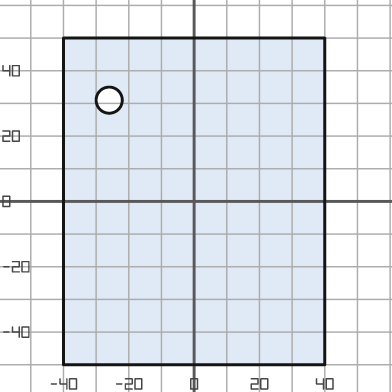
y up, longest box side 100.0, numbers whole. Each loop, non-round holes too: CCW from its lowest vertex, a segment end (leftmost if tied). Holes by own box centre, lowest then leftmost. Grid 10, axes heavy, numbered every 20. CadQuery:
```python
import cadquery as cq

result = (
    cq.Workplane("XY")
    .moveTo(-40.0, -50.0)
    .lineTo(40.0, -50.0)
    .lineTo(40.0, 50.0)
    .lineTo(-40.0, 50.0)
    .close()
    .moveTo(-26.0, 31.0)
    .circle(4.0)
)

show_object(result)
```